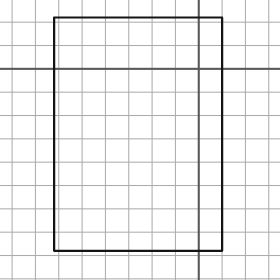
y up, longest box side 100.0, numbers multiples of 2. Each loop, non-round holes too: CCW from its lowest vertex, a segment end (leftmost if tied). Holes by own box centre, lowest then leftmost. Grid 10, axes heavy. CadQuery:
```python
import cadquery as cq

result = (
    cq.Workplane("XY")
    .moveTo(-62.0, -78.0)
    .lineTo(10.0, -78.0)
    .lineTo(10.0, 22.0)
    .lineTo(-62.0, 22.0)
    .close()
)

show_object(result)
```